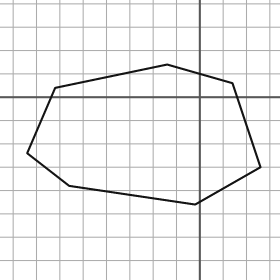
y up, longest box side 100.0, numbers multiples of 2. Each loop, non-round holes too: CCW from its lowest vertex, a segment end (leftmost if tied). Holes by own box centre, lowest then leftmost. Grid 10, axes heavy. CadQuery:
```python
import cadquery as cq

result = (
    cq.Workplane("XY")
    .moveTo(-2.0, -46.0)
    .lineTo(26.0, -30.0)
    .lineTo(14.0, 6.0)
    .lineTo(-14.0, 14.0)
    .lineTo(-62.0, 4.0)
    .lineTo(-74.0, -24.0)
    .lineTo(-56.0, -38.0)
    .close()
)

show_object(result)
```